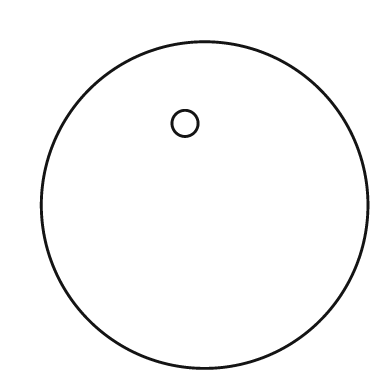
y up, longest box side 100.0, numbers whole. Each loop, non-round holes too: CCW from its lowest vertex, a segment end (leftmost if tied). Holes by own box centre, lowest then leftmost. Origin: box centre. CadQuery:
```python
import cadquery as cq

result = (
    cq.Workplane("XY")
    .moveTo(0.0, 0.0)
    .circle(50.0)
    .moveTo(-6.0, 25.0)
    .circle(4.0)
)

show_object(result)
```